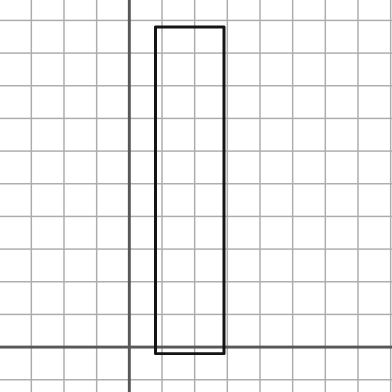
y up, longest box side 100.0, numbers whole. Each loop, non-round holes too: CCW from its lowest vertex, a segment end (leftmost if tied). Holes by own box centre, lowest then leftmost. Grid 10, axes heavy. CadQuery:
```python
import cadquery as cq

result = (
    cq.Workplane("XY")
    .moveTo(8.0, -2.0)
    .lineTo(29.0, -2.0)
    .lineTo(29.0, 98.0)
    .lineTo(8.0, 98.0)
    .close()
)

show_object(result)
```